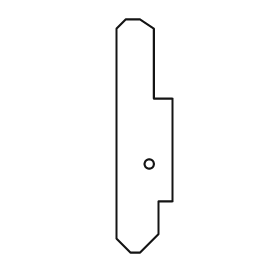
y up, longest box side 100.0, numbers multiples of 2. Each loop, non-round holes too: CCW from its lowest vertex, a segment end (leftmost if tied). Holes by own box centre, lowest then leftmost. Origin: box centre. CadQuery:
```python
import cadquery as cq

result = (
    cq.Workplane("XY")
    .moveTo(-6.0, -50.0)
    .lineTo(-2.0, -50.0)
    .lineTo(6.0, -42.0)
    .lineTo(6.0, -28.0)
    .lineTo(12.0, -28.0)
    .lineTo(12.0, 16.0)
    .lineTo(4.0, 16.0)
    .lineTo(4.0, 46.0)
    .lineTo(-2.0, 50.0)
    .lineTo(-8.0, 50.0)
    .lineTo(-12.0, 46.0)
    .lineTo(-12.0, -44.0)
    .close()
    .moveTo(2.0, -12.0)
    .circle(2.0)
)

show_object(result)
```